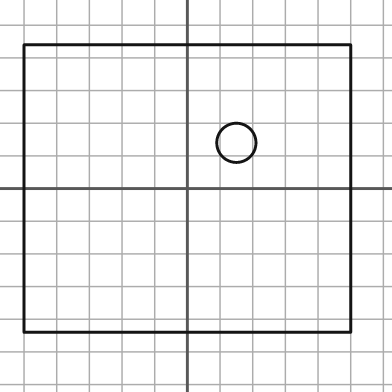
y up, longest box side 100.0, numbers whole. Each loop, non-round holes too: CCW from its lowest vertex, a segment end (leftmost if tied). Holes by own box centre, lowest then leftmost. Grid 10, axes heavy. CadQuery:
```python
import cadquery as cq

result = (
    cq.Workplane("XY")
    .moveTo(-50.0, -44.0)
    .lineTo(50.0, -44.0)
    .lineTo(50.0, 44.0)
    .lineTo(-50.0, 44.0)
    .close()
    .moveTo(15.0, 14.0)
    .circle(6.0)
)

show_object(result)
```